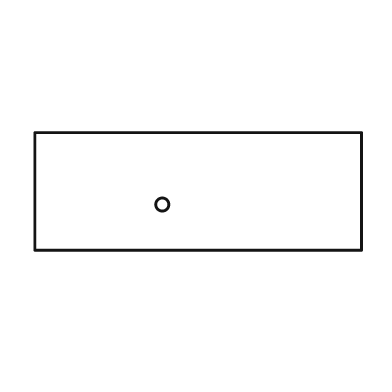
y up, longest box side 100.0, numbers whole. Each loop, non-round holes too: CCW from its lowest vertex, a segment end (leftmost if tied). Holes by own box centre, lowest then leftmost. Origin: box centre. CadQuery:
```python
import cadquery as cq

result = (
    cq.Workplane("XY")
    .moveTo(-50.0, -18.0)
    .lineTo(50.0, -18.0)
    .lineTo(50.0, 18.0)
    .lineTo(-50.0, 18.0)
    .close()
    .moveTo(-11.0, -4.0)
    .circle(2.0)
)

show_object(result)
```